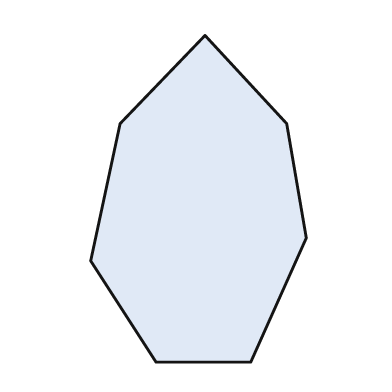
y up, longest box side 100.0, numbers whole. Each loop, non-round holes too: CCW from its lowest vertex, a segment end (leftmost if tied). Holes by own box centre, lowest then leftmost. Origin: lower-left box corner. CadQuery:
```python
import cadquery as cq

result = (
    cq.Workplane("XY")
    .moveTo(20.0, 0.0)
    .lineTo(49.0, 0.0)
    .lineTo(66.0, 38.0)
    .lineTo(60.0, 73.0)
    .lineTo(35.0, 100.0)
    .lineTo(9.0, 73.0)
    .lineTo(0.0, 31.0)
    .close()
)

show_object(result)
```